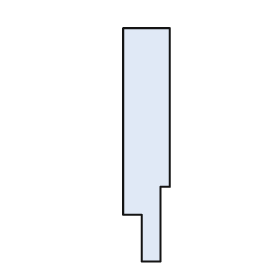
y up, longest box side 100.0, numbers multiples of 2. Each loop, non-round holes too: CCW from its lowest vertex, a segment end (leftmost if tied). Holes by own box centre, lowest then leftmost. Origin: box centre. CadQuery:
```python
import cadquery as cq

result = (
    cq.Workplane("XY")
    .moveTo(-2.0, -50.0)
    .lineTo(6.0, -50.0)
    .lineTo(6.0, -18.0)
    .lineTo(10.0, -18.0)
    .lineTo(10.0, 50.0)
    .lineTo(-10.0, 50.0)
    .lineTo(-10.0, -30.0)
    .lineTo(-2.0, -30.0)
    .close()
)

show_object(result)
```